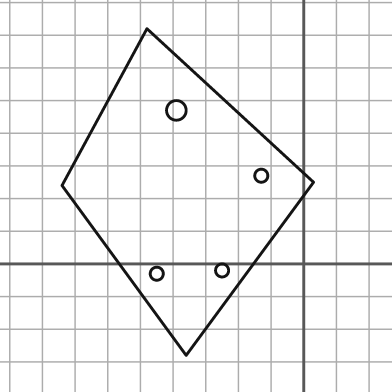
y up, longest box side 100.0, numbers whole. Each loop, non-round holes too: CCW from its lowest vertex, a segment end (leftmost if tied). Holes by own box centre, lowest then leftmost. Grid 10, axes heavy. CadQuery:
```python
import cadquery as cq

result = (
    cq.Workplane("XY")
    .moveTo(-36.0, -28.0)
    .lineTo(3.0, 25.0)
    .lineTo(-48.0, 72.0)
    .lineTo(-74.0, 24.0)
    .close()
    .moveTo(-45.0, -3.0)
    .circle(2.0)
    .moveTo(-25.0, -2.0)
    .circle(2.0)
    .moveTo(-13.0, 27.0)
    .circle(2.0)
    .moveTo(-39.0, 47.0)
    .circle(3.0)
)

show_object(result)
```